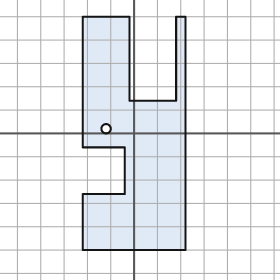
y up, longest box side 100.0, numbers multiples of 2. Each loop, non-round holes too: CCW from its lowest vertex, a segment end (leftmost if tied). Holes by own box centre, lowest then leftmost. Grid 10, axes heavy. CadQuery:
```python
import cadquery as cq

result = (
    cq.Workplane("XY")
    .moveTo(-22.0, -50.0)
    .lineTo(22.0, -50.0)
    .lineTo(22.0, 50.0)
    .lineTo(18.0, 50.0)
    .lineTo(18.0, 14.0)
    .lineTo(-2.0, 14.0)
    .lineTo(-2.0, 50.0)
    .lineTo(-22.0, 50.0)
    .lineTo(-22.0, -6.0)
    .lineTo(-4.0, -6.0)
    .lineTo(-4.0, -26.0)
    .lineTo(-22.0, -26.0)
    .close()
    .moveTo(-12.0, 2.0)
    .circle(2.0)
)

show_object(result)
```